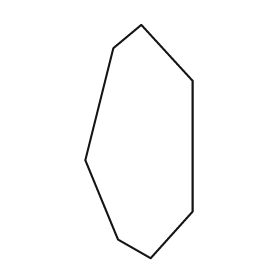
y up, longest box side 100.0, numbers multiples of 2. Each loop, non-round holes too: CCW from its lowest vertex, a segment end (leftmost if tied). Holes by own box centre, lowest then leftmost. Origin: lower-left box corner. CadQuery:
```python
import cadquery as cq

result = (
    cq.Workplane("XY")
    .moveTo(28.0, 0.0)
    .lineTo(46.0, 20.0)
    .lineTo(46.0, 76.0)
    .lineTo(24.0, 100.0)
    .lineTo(12.0, 90.0)
    .lineTo(0.0, 42.0)
    .lineTo(14.0, 8.0)
    .close()
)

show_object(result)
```